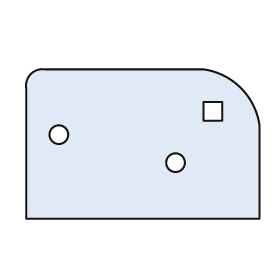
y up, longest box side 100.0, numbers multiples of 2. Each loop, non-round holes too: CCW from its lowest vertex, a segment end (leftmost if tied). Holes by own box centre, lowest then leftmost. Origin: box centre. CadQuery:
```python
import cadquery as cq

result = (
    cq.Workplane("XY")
    .moveTo(-50.0, -32.0)
    .lineTo(50.0, -32.0)
    .lineTo(50.0, 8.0)
    .threePointArc((42.0, 24.0), (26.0, 32.0))
    .lineTo(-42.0, 32.0)
    .threePointArc((-48.0, 30.0), (-50.0, 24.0))
    .close()
    .moveTo(14.0, -8.0)
    .circle(4.0)
    .moveTo(-36.0, 4.0)
    .circle(4.0)
    .moveTo(26.0, 10.0)
    .lineTo(34.0, 10.0)
    .lineTo(34.0, 18.0)
    .lineTo(26.0, 18.0)
    .close()
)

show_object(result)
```